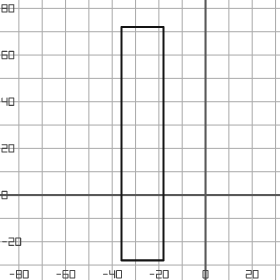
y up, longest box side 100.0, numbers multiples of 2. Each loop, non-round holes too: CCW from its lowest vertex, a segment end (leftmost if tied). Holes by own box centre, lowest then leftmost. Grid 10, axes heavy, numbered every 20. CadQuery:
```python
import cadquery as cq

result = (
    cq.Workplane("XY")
    .moveTo(-36.0, -28.0)
    .lineTo(-18.0, -28.0)
    .lineTo(-18.0, 72.0)
    .lineTo(-36.0, 72.0)
    .close()
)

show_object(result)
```